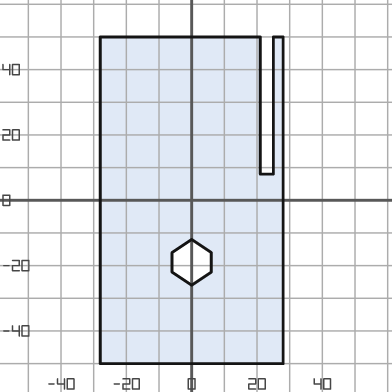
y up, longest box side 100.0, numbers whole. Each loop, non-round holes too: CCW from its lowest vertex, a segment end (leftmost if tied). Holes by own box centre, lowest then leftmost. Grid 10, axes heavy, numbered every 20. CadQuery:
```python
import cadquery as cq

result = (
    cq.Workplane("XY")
    .moveTo(-28.0, -50.0)
    .lineTo(28.0, -50.0)
    .lineTo(28.0, 50.0)
    .lineTo(25.0, 50.0)
    .lineTo(25.0, 8.0)
    .lineTo(21.0, 8.0)
    .lineTo(21.0, 50.0)
    .lineTo(-28.0, 50.0)
    .close()
    .moveTo(0.0, -26.0)
    .lineTo(6.0, -22.0)
    .lineTo(6.0, -16.0)
    .lineTo(0.0, -12.0)
    .lineTo(-6.0, -16.0)
    .lineTo(-6.0, -22.0)
    .close()
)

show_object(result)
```